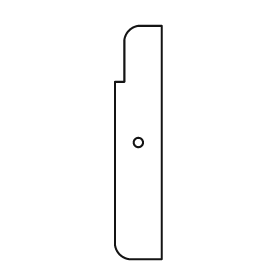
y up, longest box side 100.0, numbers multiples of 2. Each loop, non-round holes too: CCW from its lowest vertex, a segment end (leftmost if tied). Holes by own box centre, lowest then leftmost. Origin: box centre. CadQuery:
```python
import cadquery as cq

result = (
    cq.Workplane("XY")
    .moveTo(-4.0, -50.0)
    .lineTo(10.0, -50.0)
    .lineTo(10.0, 50.0)
    .lineTo(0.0, 50.0)
    .threePointArc((-4.0, 48.0), (-6.0, 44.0))
    .lineTo(-6.0, 26.0)
    .lineTo(-10.0, 26.0)
    .lineTo(-10.0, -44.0)
    .threePointArc((-8.0, -48.0), (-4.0, -50.0))
    .close()
    .moveTo(0.0, 0.0)
    .circle(2.0)
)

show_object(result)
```